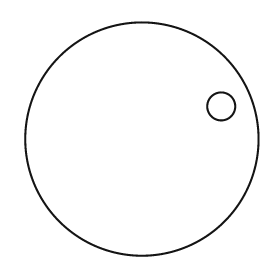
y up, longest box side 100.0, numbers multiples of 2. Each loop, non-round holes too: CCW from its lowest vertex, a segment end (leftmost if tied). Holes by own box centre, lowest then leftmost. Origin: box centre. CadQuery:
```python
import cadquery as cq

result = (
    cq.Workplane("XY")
    .moveTo(0.0, 0.0)
    .circle(50.0)
    .moveTo(34.0, 14.0)
    .circle(6.0)
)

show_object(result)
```